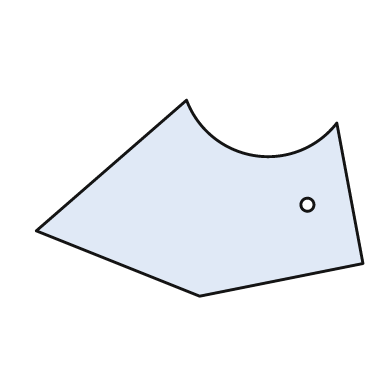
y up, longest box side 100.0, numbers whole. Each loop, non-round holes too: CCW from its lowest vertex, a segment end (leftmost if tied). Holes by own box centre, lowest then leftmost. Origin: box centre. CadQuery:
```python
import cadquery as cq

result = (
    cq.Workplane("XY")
    .moveTo(0.0, -30.0)
    .lineTo(50.0, -20.0)
    .lineTo(42.0, 23.0)
    .threePointArc((17.0, 13.0), (-4.0, 30.0))
    .lineTo(-50.0, -10.0)
    .close()
    .moveTo(33.0, -2.0)
    .circle(2.0)
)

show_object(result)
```